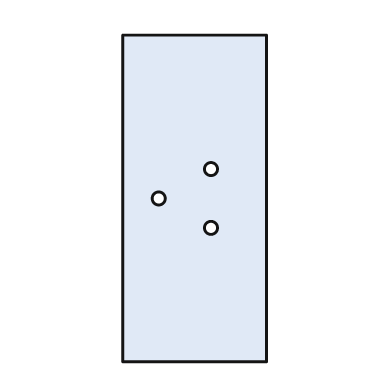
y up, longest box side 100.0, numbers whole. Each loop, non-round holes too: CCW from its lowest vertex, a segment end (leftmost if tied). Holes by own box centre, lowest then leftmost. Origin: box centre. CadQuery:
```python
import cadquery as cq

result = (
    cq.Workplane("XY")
    .moveTo(-22.0, -50.0)
    .lineTo(22.0, -50.0)
    .lineTo(22.0, 50.0)
    .lineTo(-22.0, 50.0)
    .close()
    .moveTo(5.0, -9.0)
    .circle(2.0)
    .moveTo(-11.0, 0.0)
    .circle(2.0)
    .moveTo(5.0, 9.0)
    .circle(2.0)
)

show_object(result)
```